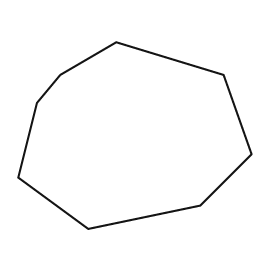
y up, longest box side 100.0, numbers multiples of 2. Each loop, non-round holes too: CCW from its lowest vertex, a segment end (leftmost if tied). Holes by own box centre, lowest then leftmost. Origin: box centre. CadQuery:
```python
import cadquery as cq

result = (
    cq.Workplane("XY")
    .moveTo(-20.0, -40.0)
    .lineTo(28.0, -30.0)
    .lineTo(50.0, -8.0)
    .lineTo(38.0, 26.0)
    .lineTo(-8.0, 40.0)
    .lineTo(-32.0, 26.0)
    .lineTo(-42.0, 14.0)
    .lineTo(-50.0, -18.0)
    .close()
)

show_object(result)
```